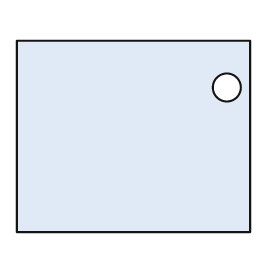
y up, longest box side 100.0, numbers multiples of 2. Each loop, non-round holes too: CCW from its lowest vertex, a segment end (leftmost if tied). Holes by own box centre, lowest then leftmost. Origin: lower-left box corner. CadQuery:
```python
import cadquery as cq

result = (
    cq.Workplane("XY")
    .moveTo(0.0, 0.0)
    .lineTo(100.0, 0.0)
    .lineTo(100.0, 82.0)
    .lineTo(0.0, 82.0)
    .close()
    .moveTo(90.0, 62.0)
    .circle(6.0)
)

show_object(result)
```